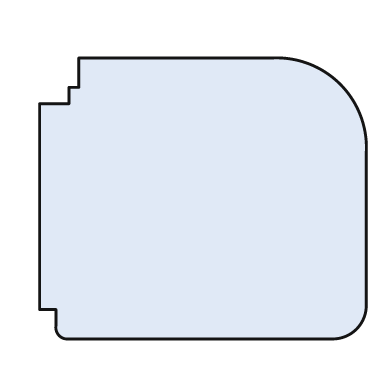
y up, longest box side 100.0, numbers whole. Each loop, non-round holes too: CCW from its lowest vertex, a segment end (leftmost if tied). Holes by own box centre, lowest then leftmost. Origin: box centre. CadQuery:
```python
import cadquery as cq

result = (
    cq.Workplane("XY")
    .moveTo(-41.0, -43.0)
    .lineTo(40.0, -43.0)
    .threePointArc((47.0, -40.0), (50.0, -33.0))
    .lineTo(50.0, 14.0)
    .threePointArc((42.0, 35.0), (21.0, 43.0))
    .lineTo(-38.0, 43.0)
    .lineTo(-38.0, 34.0)
    .lineTo(-41.0, 34.0)
    .lineTo(-41.0, 29.0)
    .lineTo(-50.0, 29.0)
    .lineTo(-50.0, -34.0)
    .lineTo(-45.0, -34.0)
    .lineTo(-45.0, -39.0)
    .threePointArc((-44.0, -42.0), (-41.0, -43.0))
    .close()
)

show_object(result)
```